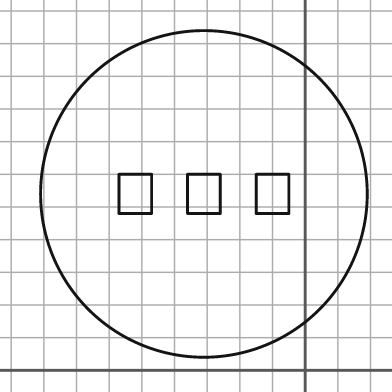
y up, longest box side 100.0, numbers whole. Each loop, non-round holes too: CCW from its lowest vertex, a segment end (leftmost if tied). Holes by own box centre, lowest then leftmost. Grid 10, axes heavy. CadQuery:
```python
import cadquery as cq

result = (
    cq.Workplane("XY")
    .moveTo(-31.0, 54.0)
    .circle(50.0)
    .moveTo(-57.0, 48.0)
    .lineTo(-47.0, 48.0)
    .lineTo(-47.0, 60.0)
    .lineTo(-57.0, 60.0)
    .close()
    .moveTo(-36.0, 48.0)
    .lineTo(-26.0, 48.0)
    .lineTo(-26.0, 60.0)
    .lineTo(-36.0, 60.0)
    .close()
    .moveTo(-15.0, 48.0)
    .lineTo(-5.0, 48.0)
    .lineTo(-5.0, 60.0)
    .lineTo(-15.0, 60.0)
    .close()
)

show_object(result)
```